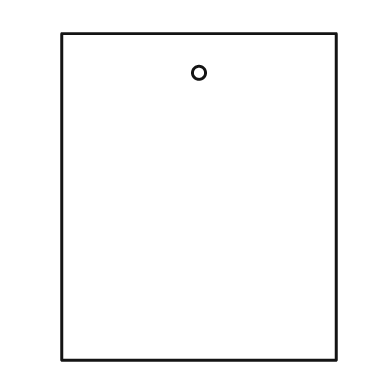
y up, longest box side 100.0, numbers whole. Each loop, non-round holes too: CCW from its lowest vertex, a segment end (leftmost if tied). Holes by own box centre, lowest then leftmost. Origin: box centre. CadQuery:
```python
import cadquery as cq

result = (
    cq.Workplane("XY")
    .moveTo(-42.0, -50.0)
    .lineTo(42.0, -50.0)
    .lineTo(42.0, 50.0)
    .lineTo(-42.0, 50.0)
    .close()
    .moveTo(0.0, 38.0)
    .circle(2.0)
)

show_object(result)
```